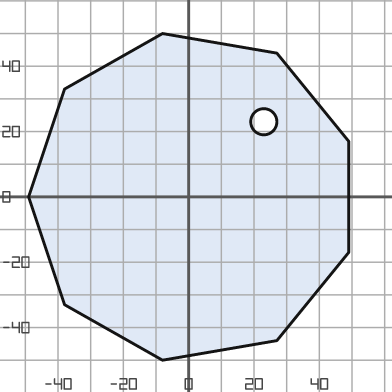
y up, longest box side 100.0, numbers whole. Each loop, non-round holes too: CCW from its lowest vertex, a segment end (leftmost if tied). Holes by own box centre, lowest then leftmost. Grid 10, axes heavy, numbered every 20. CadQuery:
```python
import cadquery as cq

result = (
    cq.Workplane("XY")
    .moveTo(-8.0, -50.0)
    .lineTo(27.0, -44.0)
    .lineTo(49.0, -17.0)
    .lineTo(49.0, 17.0)
    .lineTo(27.0, 44.0)
    .lineTo(-8.0, 50.0)
    .lineTo(-38.0, 33.0)
    .lineTo(-49.0, 0.0)
    .lineTo(-38.0, -33.0)
    .close()
    .moveTo(23.0, 23.0)
    .circle(4.0)
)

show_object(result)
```